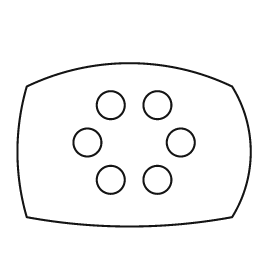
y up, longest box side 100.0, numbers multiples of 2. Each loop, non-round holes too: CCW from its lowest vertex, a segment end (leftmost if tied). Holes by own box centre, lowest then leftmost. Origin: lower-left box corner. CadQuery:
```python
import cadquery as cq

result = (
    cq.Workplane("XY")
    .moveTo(4.0, 4.0)
    .threePointArc((48.0, 0.0), (92.0, 4.0))
    .threePointArc((100.0, 32.0), (92.0, 60.0))
    .threePointArc((48.0, 70.0), (4.0, 60.0))
    .threePointArc((0.0, 32.0), (4.0, 4.0))
    .close()
    .moveTo(40.0, 20.0)
    .circle(6.0)
    .moveTo(60.0, 20.0)
    .circle(6.0)
    .moveTo(30.0, 36.0)
    .circle(6.0)
    .moveTo(70.0, 36.0)
    .circle(6.0)
    .moveTo(40.0, 52.0)
    .circle(6.0)
    .moveTo(60.0, 52.0)
    .circle(6.0)
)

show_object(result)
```